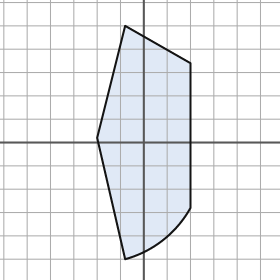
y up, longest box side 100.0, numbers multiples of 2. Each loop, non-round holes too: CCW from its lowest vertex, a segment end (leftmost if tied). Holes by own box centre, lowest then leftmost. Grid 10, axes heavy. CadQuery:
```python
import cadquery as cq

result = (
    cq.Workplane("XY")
    .moveTo(-8.0, -50.0)
    .threePointArc((8.0, -42.0), (20.0, -28.0))
    .lineTo(20.0, 34.0)
    .lineTo(-8.0, 50.0)
    .lineTo(-20.0, 2.0)
    .close()
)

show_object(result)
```